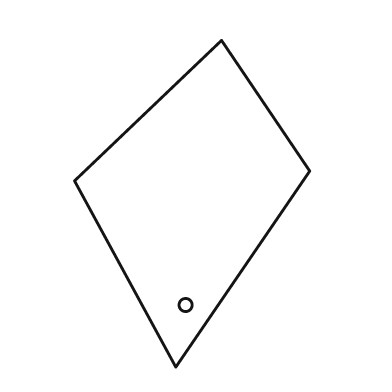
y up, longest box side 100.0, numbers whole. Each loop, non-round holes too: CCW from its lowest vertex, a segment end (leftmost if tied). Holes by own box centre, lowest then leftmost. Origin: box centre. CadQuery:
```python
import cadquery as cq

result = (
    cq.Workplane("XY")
    .moveTo(-5.0, -50.0)
    .lineTo(36.0, 10.0)
    .lineTo(9.0, 50.0)
    .lineTo(-36.0, 7.0)
    .close()
    .moveTo(-2.0, -31.0)
    .circle(2.0)
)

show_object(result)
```